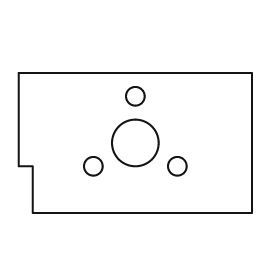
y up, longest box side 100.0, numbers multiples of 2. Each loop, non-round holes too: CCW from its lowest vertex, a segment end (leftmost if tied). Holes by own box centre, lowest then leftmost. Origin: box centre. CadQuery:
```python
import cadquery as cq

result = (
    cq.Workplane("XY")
    .moveTo(-44.0, -30.0)
    .lineTo(50.0, -30.0)
    .lineTo(50.0, 30.0)
    .lineTo(-50.0, 30.0)
    .lineTo(-50.0, -10.0)
    .lineTo(-44.0, -10.0)
    .close()
    .moveTo(-18.0, -10.0)
    .circle(4.0)
    .moveTo(18.0, -10.0)
    .circle(4.0)
    .moveTo(0.0, 0.0)
    .circle(10.0)
    .moveTo(0.0, 20.0)
    .circle(4.0)
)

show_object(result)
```